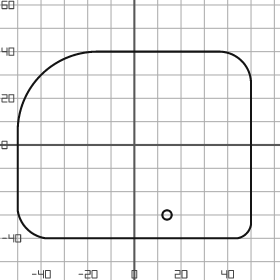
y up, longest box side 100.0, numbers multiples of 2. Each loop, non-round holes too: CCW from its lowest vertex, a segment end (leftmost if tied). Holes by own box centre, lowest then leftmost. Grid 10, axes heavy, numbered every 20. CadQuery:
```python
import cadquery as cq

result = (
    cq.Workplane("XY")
    .moveTo(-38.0, -40.0)
    .lineTo(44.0, -40.0)
    .threePointArc((48.0, -38.0), (50.0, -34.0))
    .lineTo(50.0, 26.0)
    .threePointArc((46.0, 36.0), (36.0, 40.0))
    .lineTo(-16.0, 40.0)
    .threePointArc((-40.0, 30.0), (-50.0, 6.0))
    .lineTo(-50.0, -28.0)
    .threePointArc((-46.0, -36.0), (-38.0, -40.0))
    .close()
    .moveTo(14.0, -30.0)
    .circle(2.0)
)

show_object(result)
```